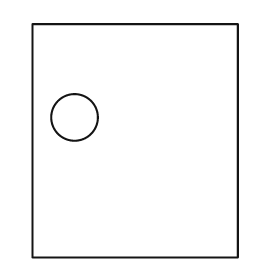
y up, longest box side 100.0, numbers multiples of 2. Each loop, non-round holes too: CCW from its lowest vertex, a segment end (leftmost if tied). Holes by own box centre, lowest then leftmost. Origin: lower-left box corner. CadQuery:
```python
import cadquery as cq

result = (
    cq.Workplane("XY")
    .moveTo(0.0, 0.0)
    .lineTo(88.0, 0.0)
    .lineTo(88.0, 100.0)
    .lineTo(0.0, 100.0)
    .close()
    .moveTo(18.0, 60.0)
    .circle(10.0)
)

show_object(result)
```